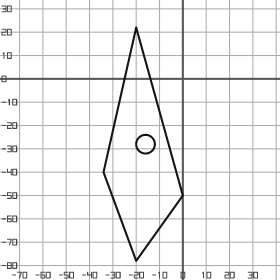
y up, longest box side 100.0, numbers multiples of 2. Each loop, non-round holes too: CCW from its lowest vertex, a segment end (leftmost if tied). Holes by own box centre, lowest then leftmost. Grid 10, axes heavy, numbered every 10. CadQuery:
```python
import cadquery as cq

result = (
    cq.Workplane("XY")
    .moveTo(-20.0, -78.0)
    .lineTo(0.0, -50.0)
    .lineTo(-20.0, 22.0)
    .lineTo(-34.0, -40.0)
    .close()
    .moveTo(-16.0, -28.0)
    .circle(4.0)
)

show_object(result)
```